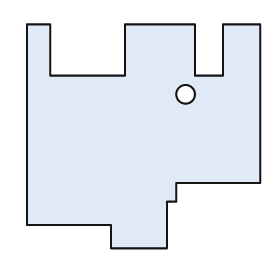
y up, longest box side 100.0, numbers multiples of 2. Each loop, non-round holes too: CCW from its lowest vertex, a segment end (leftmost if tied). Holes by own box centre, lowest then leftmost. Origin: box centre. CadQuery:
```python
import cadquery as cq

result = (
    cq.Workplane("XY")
    .moveTo(-14.0, -48.0)
    .lineTo(10.0, -48.0)
    .lineTo(10.0, -28.0)
    .lineTo(14.0, -28.0)
    .lineTo(14.0, -20.0)
    .lineTo(50.0, -20.0)
    .lineTo(50.0, 48.0)
    .lineTo(34.0, 48.0)
    .lineTo(34.0, 26.0)
    .lineTo(22.0, 26.0)
    .lineTo(22.0, 48.0)
    .lineTo(-8.0, 48.0)
    .lineTo(-8.0, 26.0)
    .lineTo(-40.0, 26.0)
    .lineTo(-40.0, 48.0)
    .lineTo(-50.0, 48.0)
    .lineTo(-50.0, -38.0)
    .lineTo(-14.0, -38.0)
    .close()
    .moveTo(18.0, 18.0)
    .circle(4.0)
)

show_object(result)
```